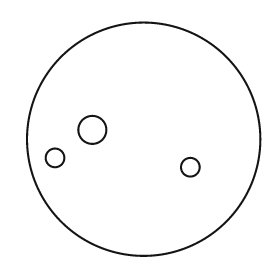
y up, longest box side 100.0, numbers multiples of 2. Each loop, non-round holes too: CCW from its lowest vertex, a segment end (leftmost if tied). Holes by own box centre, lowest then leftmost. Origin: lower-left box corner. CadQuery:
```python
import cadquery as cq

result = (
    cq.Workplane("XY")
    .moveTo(50.0, 50.0)
    .circle(50.0)
    .moveTo(70.0, 38.0)
    .circle(4.0)
    .moveTo(12.0, 42.0)
    .circle(4.0)
    .moveTo(28.0, 54.0)
    .circle(6.0)
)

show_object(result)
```